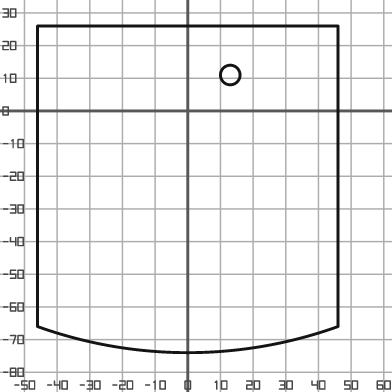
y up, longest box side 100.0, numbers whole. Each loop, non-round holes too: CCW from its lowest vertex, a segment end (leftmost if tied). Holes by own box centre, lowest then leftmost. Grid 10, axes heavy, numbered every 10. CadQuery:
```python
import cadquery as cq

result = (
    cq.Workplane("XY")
    .moveTo(-46.0, -66.0)
    .threePointArc((0.0, -74.0), (46.0, -66.0))
    .lineTo(46.0, 26.0)
    .lineTo(-46.0, 26.0)
    .close()
    .moveTo(13.0, 11.0)
    .circle(3.0)
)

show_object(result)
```